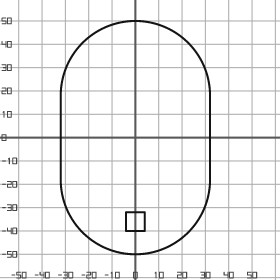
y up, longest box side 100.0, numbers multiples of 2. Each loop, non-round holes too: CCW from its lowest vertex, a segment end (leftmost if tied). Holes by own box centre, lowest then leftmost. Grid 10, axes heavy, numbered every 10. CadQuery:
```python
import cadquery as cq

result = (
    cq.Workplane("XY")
    .moveTo(-32.0, -18.0)
    .threePointArc((0.0, -50.0), (32.0, -18.0))
    .lineTo(32.0, 18.0)
    .threePointArc((0.0, 50.0), (-32.0, 18.0))
    .close()
    .moveTo(-4.0, -40.0)
    .lineTo(4.0, -40.0)
    .lineTo(4.0, -32.0)
    .lineTo(-4.0, -32.0)
    .close()
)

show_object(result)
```